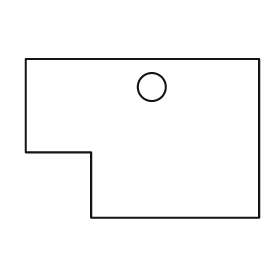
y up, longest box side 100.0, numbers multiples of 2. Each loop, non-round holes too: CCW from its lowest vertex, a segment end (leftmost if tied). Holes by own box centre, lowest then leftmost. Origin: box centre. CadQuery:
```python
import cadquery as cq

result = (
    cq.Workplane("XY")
    .moveTo(-22.0, -34.0)
    .lineTo(50.0, -34.0)
    .lineTo(50.0, 34.0)
    .lineTo(-50.0, 34.0)
    .lineTo(-50.0, -6.0)
    .lineTo(-22.0, -6.0)
    .close()
    .moveTo(4.0, 22.0)
    .circle(6.0)
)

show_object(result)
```